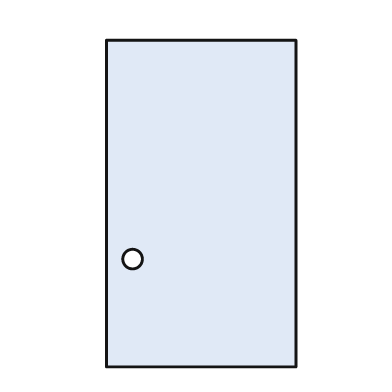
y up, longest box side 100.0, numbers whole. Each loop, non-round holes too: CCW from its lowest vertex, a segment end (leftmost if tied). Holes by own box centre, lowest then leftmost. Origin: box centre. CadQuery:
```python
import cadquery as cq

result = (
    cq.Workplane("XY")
    .moveTo(-29.0, -50.0)
    .lineTo(29.0, -50.0)
    .lineTo(29.0, 50.0)
    .lineTo(-29.0, 50.0)
    .close()
    .moveTo(-21.0, -17.0)
    .circle(3.0)
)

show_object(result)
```